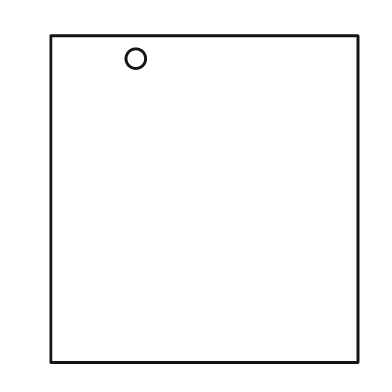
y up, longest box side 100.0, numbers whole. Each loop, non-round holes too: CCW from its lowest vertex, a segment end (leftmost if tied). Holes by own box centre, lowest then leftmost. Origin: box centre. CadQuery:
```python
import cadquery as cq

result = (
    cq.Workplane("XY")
    .moveTo(-47.0, -50.0)
    .lineTo(47.0, -50.0)
    .lineTo(47.0, 50.0)
    .lineTo(-47.0, 50.0)
    .close()
    .moveTo(-21.0, 43.0)
    .circle(3.0)
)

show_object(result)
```